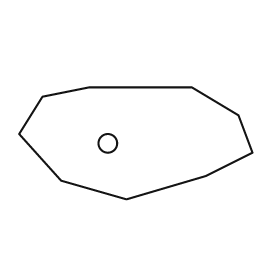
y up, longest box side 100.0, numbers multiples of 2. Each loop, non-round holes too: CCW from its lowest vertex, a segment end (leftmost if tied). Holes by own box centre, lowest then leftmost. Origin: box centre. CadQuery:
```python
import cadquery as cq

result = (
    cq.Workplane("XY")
    .moveTo(-4.0, -24.0)
    .lineTo(30.0, -14.0)
    .lineTo(50.0, -4.0)
    .lineTo(44.0, 12.0)
    .lineTo(24.0, 24.0)
    .lineTo(-20.0, 24.0)
    .lineTo(-40.0, 20.0)
    .lineTo(-50.0, 4.0)
    .lineTo(-32.0, -16.0)
    .close()
    .moveTo(-12.0, 0.0)
    .circle(4.0)
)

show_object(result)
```